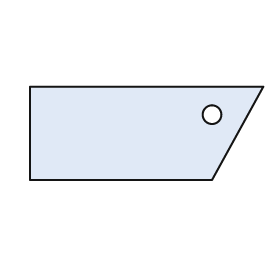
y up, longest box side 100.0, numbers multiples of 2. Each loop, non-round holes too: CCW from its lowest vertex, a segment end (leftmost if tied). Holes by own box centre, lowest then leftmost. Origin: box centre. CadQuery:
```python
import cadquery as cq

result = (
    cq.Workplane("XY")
    .moveTo(-50.0, -20.0)
    .lineTo(28.0, -20.0)
    .lineTo(50.0, 20.0)
    .lineTo(-50.0, 20.0)
    .close()
    .moveTo(28.0, 8.0)
    .circle(4.0)
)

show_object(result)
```